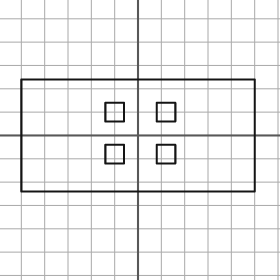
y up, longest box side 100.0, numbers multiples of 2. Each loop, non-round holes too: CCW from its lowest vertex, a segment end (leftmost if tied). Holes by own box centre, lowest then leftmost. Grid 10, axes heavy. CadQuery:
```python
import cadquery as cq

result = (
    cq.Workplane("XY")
    .moveTo(-50.0, -24.0)
    .lineTo(50.0, -24.0)
    .lineTo(50.0, 24.0)
    .lineTo(-50.0, 24.0)
    .close()
    .moveTo(-14.0, -12.0)
    .lineTo(-6.0, -12.0)
    .lineTo(-6.0, -4.0)
    .lineTo(-14.0, -4.0)
    .close()
    .moveTo(8.0, -12.0)
    .lineTo(16.0, -12.0)
    .lineTo(16.0, -4.0)
    .lineTo(8.0, -4.0)
    .close()
    .moveTo(-14.0, 6.0)
    .lineTo(-6.0, 6.0)
    .lineTo(-6.0, 14.0)
    .lineTo(-14.0, 14.0)
    .close()
    .moveTo(8.0, 6.0)
    .lineTo(16.0, 6.0)
    .lineTo(16.0, 14.0)
    .lineTo(8.0, 14.0)
    .close()
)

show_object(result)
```